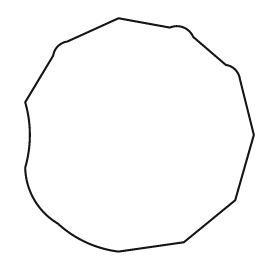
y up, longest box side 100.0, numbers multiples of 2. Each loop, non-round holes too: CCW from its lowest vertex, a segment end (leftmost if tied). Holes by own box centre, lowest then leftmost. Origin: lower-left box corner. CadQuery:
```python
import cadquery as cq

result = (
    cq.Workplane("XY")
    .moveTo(40.0, 0.0)
    .lineTo(68.0, 4.0)
    .lineTo(90.0, 22.0)
    .lineTo(98.0, 50.0)
    .lineTo(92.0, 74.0)
    .threePointArc((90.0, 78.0), (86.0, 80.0))
    .lineTo(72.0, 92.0)
    .threePointArc((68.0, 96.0), (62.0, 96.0))
    .lineTo(40.0, 100.0)
    .lineTo(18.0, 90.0)
    .threePointArc((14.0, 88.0), (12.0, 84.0))
    .lineTo(0.0, 64.0)
    .threePointArc((2.0, 50.0), (0.0, 36.0))
    .threePointArc((4.0, 22.0), (14.0, 12.0))
    .threePointArc((26.0, 4.0), (40.0, 0.0))
    .close()
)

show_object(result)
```